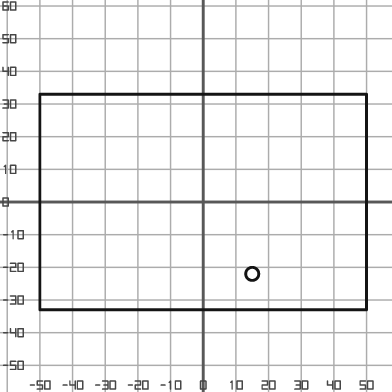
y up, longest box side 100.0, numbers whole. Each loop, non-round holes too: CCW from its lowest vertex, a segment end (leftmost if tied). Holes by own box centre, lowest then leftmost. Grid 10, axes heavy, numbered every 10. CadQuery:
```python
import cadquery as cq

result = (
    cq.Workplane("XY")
    .moveTo(-50.0, -33.0)
    .lineTo(50.0, -33.0)
    .lineTo(50.0, 33.0)
    .lineTo(-50.0, 33.0)
    .close()
    .moveTo(15.0, -22.0)
    .circle(2.0)
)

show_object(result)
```